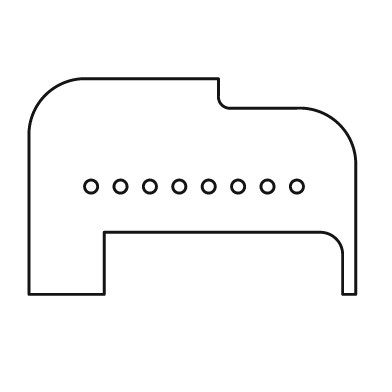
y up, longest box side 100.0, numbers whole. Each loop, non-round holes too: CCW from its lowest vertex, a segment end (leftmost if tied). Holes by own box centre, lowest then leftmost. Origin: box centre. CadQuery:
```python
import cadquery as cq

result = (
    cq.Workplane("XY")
    .moveTo(-50.0, -33.0)
    .lineTo(-27.0, -33.0)
    .lineTo(-27.0, -14.0)
    .lineTo(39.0, -14.0)
    .threePointArc((44.0, -16.0), (46.0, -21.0))
    .lineTo(46.0, -33.0)
    .lineTo(50.0, -33.0)
    .lineTo(50.0, 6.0)
    .threePointArc((45.0, 19.0), (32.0, 24.0))
    .lineTo(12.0, 24.0)
    .threePointArc((9.0, 25.0), (8.0, 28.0))
    .lineTo(8.0, 33.0)
    .lineTo(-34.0, 33.0)
    .threePointArc((-45.0, 28.0), (-50.0, 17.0))
    .close()
    .moveTo(-31.0, 0.0)
    .circle(2.0)
    .moveTo(-22.0, 0.0)
    .circle(2.0)
    .moveTo(-13.0, 0.0)
    .circle(2.0)
    .moveTo(-4.0, 0.0)
    .circle(2.0)
    .moveTo(5.0, 0.0)
    .circle(2.0)
    .moveTo(14.0, 0.0)
    .circle(2.0)
    .moveTo(23.0, 0.0)
    .circle(2.0)
    .moveTo(32.0, 0.0)
    .circle(2.0)
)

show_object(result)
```